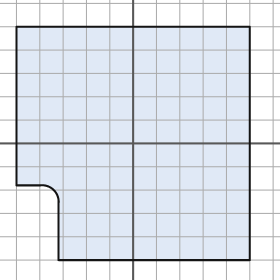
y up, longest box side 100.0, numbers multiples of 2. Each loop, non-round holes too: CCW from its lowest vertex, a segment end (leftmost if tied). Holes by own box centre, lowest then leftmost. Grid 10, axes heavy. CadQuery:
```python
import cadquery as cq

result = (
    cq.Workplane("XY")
    .moveTo(-32.0, -50.0)
    .lineTo(50.0, -50.0)
    .lineTo(50.0, 50.0)
    .lineTo(-50.0, 50.0)
    .lineTo(-50.0, -18.0)
    .lineTo(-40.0, -18.0)
    .threePointArc((-34.0, -20.0), (-32.0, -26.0))
    .close()
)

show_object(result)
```